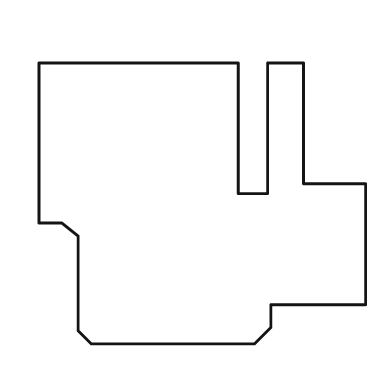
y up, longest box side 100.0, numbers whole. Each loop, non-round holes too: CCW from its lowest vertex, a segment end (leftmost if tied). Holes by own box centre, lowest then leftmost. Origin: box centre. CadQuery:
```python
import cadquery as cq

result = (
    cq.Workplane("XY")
    .moveTo(-34.0, -43.0)
    .lineTo(16.0, -43.0)
    .lineTo(21.0, -38.0)
    .lineTo(21.0, -31.0)
    .lineTo(50.0, -31.0)
    .lineTo(50.0, 6.0)
    .lineTo(31.0, 6.0)
    .lineTo(31.0, 43.0)
    .lineTo(20.0, 43.0)
    .lineTo(20.0, 3.0)
    .lineTo(11.0, 3.0)
    .lineTo(11.0, 43.0)
    .lineTo(-50.0, 43.0)
    .lineTo(-50.0, -6.0)
    .lineTo(-43.0, -6.0)
    .lineTo(-38.0, -10.0)
    .lineTo(-38.0, -39.0)
    .close()
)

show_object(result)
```